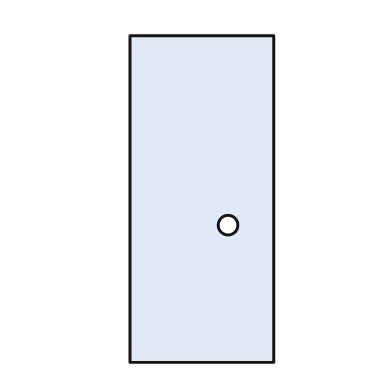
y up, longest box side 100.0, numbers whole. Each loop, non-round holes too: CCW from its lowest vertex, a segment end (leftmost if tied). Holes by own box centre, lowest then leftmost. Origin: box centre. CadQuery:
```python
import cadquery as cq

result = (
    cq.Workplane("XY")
    .moveTo(-22.0, -50.0)
    .lineTo(22.0, -50.0)
    .lineTo(22.0, 50.0)
    .lineTo(-22.0, 50.0)
    .close()
    .moveTo(8.0, -8.0)
    .circle(3.0)
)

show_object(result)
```